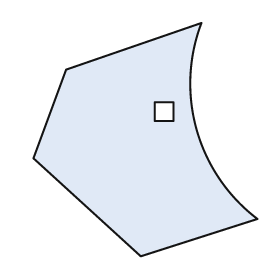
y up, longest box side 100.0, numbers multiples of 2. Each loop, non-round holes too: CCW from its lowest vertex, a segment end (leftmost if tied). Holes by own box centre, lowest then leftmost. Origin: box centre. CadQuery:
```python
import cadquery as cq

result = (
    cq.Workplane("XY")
    .moveTo(-2.0, -50.0)
    .lineTo(48.0, -34.0)
    .threePointArc((22.0, 4.0), (24.0, 50.0))
    .lineTo(-34.0, 30.0)
    .lineTo(-48.0, -8.0)
    .close()
    .moveTo(4.0, 8.0)
    .lineTo(12.0, 8.0)
    .lineTo(12.0, 16.0)
    .lineTo(4.0, 16.0)
    .close()
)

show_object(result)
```